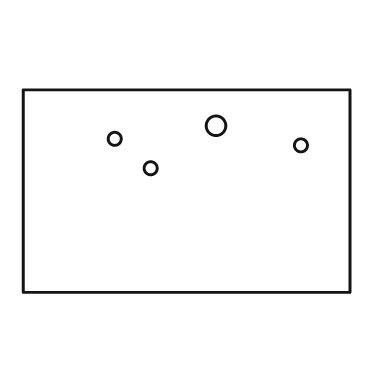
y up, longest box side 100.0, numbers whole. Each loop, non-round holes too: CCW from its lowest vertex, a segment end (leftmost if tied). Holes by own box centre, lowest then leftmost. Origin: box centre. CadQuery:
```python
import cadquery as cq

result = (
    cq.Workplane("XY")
    .moveTo(-50.0, -31.0)
    .lineTo(50.0, -31.0)
    .lineTo(50.0, 31.0)
    .lineTo(-50.0, 31.0)
    .close()
    .moveTo(-11.0, 7.0)
    .circle(2.0)
    .moveTo(35.0, 14.0)
    .circle(2.0)
    .moveTo(-22.0, 16.0)
    .circle(2.0)
    .moveTo(9.0, 20.0)
    .circle(3.0)
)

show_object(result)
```